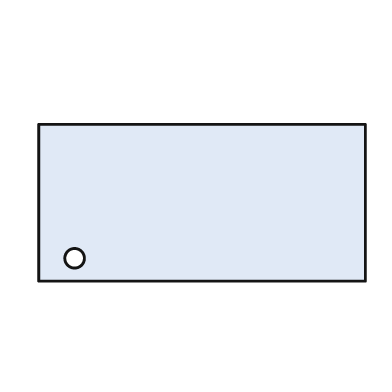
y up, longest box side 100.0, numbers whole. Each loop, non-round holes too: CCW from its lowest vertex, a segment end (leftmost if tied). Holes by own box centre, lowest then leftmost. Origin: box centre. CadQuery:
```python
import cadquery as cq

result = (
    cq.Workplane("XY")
    .moveTo(-50.0, -24.0)
    .lineTo(50.0, -24.0)
    .lineTo(50.0, 24.0)
    .lineTo(-50.0, 24.0)
    .close()
    .moveTo(-39.0, -17.0)
    .circle(3.0)
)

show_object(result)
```